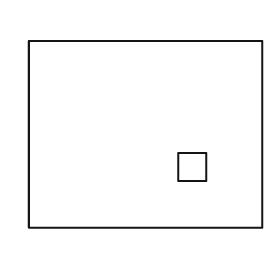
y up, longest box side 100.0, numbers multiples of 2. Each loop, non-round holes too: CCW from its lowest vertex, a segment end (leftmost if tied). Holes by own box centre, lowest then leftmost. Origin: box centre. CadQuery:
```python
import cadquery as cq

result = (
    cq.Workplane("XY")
    .moveTo(-50.0, -40.0)
    .lineTo(50.0, -40.0)
    .lineTo(50.0, 40.0)
    .lineTo(-50.0, 40.0)
    .close()
    .moveTo(14.0, -20.0)
    .lineTo(26.0, -20.0)
    .lineTo(26.0, -8.0)
    .lineTo(14.0, -8.0)
    .close()
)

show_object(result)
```